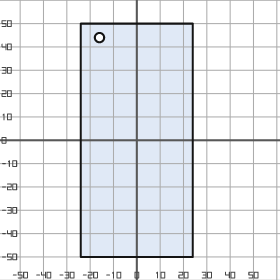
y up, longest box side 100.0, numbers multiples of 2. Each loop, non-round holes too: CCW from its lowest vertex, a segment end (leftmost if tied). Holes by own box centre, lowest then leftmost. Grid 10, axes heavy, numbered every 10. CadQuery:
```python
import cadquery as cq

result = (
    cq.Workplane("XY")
    .moveTo(-24.0, -50.0)
    .lineTo(24.0, -50.0)
    .lineTo(24.0, 50.0)
    .lineTo(-24.0, 50.0)
    .close()
    .moveTo(-16.0, 44.0)
    .circle(2.0)
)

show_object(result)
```